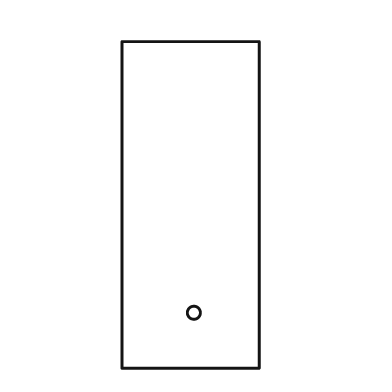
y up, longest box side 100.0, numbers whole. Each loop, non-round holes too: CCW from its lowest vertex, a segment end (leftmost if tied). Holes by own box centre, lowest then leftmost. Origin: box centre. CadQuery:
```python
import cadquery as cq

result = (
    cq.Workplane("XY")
    .moveTo(-21.0, -50.0)
    .lineTo(21.0, -50.0)
    .lineTo(21.0, 50.0)
    .lineTo(-21.0, 50.0)
    .close()
    .moveTo(1.0, -33.0)
    .circle(2.0)
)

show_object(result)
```